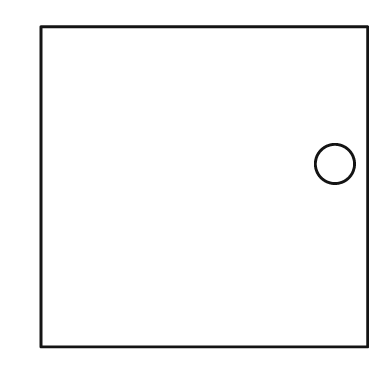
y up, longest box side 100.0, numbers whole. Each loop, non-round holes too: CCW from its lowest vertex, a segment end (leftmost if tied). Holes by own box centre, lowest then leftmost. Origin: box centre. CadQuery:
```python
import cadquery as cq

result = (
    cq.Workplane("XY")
    .moveTo(-50.0, -49.0)
    .lineTo(50.0, -49.0)
    .lineTo(50.0, 49.0)
    .lineTo(-50.0, 49.0)
    .close()
    .moveTo(40.0, 7.0)
    .circle(6.0)
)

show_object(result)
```